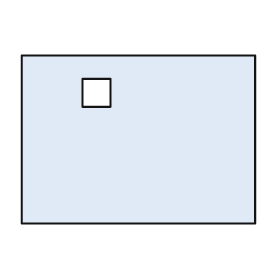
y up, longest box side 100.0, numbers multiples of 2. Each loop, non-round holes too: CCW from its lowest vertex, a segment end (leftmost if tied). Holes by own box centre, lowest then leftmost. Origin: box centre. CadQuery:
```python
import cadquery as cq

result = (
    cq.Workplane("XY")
    .moveTo(-50.0, -36.0)
    .lineTo(50.0, -36.0)
    .lineTo(50.0, 36.0)
    .lineTo(-50.0, 36.0)
    .close()
    .moveTo(-24.0, 14.0)
    .lineTo(-12.0, 14.0)
    .lineTo(-12.0, 26.0)
    .lineTo(-24.0, 26.0)
    .close()
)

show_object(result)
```